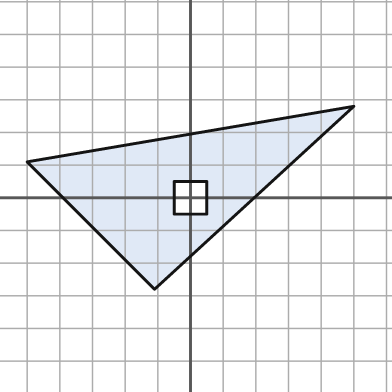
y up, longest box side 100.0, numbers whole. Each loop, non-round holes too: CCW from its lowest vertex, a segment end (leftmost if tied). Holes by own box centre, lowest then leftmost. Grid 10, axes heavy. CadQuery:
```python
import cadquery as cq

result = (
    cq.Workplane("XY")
    .moveTo(-11.0, -28.0)
    .lineTo(50.0, 28.0)
    .lineTo(-50.0, 11.0)
    .close()
    .moveTo(-5.0, -5.0)
    .lineTo(5.0, -5.0)
    .lineTo(5.0, 5.0)
    .lineTo(-5.0, 5.0)
    .close()
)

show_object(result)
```